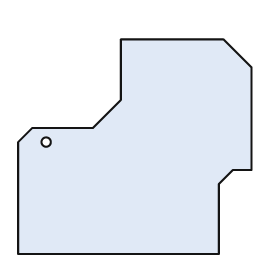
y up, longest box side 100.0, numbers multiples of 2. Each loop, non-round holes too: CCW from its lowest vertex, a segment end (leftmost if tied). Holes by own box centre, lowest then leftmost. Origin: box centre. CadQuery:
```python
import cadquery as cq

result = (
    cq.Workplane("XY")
    .moveTo(-50.0, -46.0)
    .lineTo(36.0, -46.0)
    .lineTo(36.0, -16.0)
    .lineTo(42.0, -10.0)
    .lineTo(50.0, -10.0)
    .lineTo(50.0, 34.0)
    .lineTo(38.0, 46.0)
    .lineTo(-6.0, 46.0)
    .lineTo(-6.0, 20.0)
    .lineTo(-18.0, 8.0)
    .lineTo(-44.0, 8.0)
    .lineTo(-50.0, 2.0)
    .close()
    .moveTo(-38.0, 2.0)
    .circle(2.0)
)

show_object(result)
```